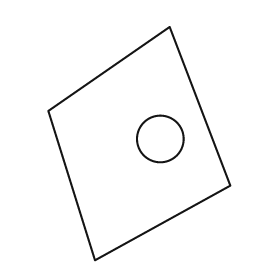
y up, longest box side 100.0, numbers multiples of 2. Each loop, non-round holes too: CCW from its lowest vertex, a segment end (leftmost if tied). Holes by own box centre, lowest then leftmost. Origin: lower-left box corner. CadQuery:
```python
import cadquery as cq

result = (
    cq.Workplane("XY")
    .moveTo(20.0, 0.0)
    .lineTo(78.0, 32.0)
    .lineTo(52.0, 100.0)
    .lineTo(0.0, 64.0)
    .close()
    .moveTo(48.0, 52.0)
    .circle(10.0)
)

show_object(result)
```